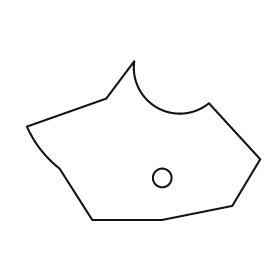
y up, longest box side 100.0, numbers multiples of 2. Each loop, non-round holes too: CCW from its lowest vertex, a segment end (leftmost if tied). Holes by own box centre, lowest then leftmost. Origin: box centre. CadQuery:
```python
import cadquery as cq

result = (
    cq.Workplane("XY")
    .moveTo(-22.0, -34.0)
    .lineTo(8.0, -34.0)
    .lineTo(38.0, -28.0)
    .lineTo(50.0, -8.0)
    .lineTo(28.0, 16.0)
    .threePointArc((6.0, 14.0), (-4.0, 34.0))
    .lineTo(-16.0, 18.0)
    .lineTo(-50.0, 6.0)
    .threePointArc((-44.0, -4.0), (-36.0, -12.0))
    .close()
    .moveTo(8.0, -16.0)
    .circle(4.0)
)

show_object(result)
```